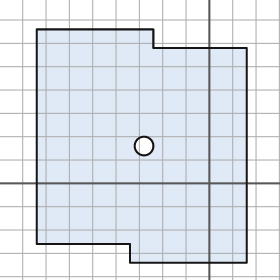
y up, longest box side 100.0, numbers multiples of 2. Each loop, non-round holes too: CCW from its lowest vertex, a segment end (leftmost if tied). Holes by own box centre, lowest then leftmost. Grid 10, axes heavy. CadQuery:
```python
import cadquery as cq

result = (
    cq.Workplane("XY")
    .moveTo(-34.0, -34.0)
    .lineTo(16.0, -34.0)
    .lineTo(16.0, 58.0)
    .lineTo(-24.0, 58.0)
    .lineTo(-24.0, 66.0)
    .lineTo(-74.0, 66.0)
    .lineTo(-74.0, -26.0)
    .lineTo(-34.0, -26.0)
    .close()
    .moveTo(-28.0, 16.0)
    .circle(4.0)
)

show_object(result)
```